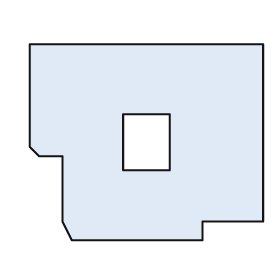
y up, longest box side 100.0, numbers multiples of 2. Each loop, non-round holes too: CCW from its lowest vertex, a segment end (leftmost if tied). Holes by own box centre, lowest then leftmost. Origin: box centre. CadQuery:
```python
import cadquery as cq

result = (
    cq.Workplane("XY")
    .moveTo(-32.0, -42.0)
    .lineTo(24.0, -42.0)
    .lineTo(24.0, -34.0)
    .lineTo(50.0, -34.0)
    .lineTo(50.0, 42.0)
    .lineTo(-50.0, 42.0)
    .lineTo(-50.0, -2.0)
    .lineTo(-46.0, -6.0)
    .lineTo(-36.0, -6.0)
    .lineTo(-36.0, -34.0)
    .close()
    .moveTo(-10.0, -12.0)
    .lineTo(10.0, -12.0)
    .lineTo(10.0, 12.0)
    .lineTo(-10.0, 12.0)
    .close()
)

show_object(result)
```